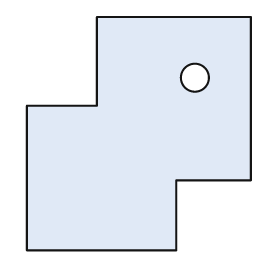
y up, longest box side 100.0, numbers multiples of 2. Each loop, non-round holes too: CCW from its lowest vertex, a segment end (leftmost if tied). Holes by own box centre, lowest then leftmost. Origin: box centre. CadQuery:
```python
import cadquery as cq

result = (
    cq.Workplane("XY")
    .moveTo(-48.0, -50.0)
    .lineTo(16.0, -50.0)
    .lineTo(16.0, -20.0)
    .lineTo(48.0, -20.0)
    .lineTo(48.0, 50.0)
    .lineTo(-18.0, 50.0)
    .lineTo(-18.0, 12.0)
    .lineTo(-48.0, 12.0)
    .close()
    .moveTo(24.0, 24.0)
    .circle(6.0)
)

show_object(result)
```